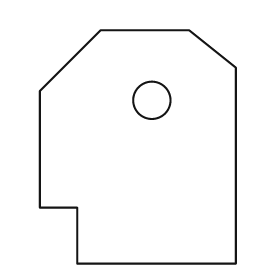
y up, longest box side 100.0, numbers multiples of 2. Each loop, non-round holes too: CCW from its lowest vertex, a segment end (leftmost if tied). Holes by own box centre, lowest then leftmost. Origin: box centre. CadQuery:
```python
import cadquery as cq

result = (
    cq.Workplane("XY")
    .moveTo(-26.0, -50.0)
    .lineTo(42.0, -50.0)
    .lineTo(42.0, 34.0)
    .lineTo(22.0, 50.0)
    .lineTo(-16.0, 50.0)
    .lineTo(-42.0, 24.0)
    .lineTo(-42.0, -26.0)
    .lineTo(-26.0, -26.0)
    .close()
    .moveTo(6.0, 20.0)
    .circle(8.0)
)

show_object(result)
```